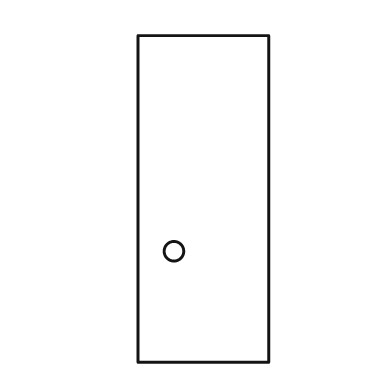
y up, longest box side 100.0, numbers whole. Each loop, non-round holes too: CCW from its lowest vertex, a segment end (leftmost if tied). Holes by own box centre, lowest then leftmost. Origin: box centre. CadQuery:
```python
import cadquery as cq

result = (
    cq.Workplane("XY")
    .moveTo(-20.0, -50.0)
    .lineTo(20.0, -50.0)
    .lineTo(20.0, 50.0)
    .lineTo(-20.0, 50.0)
    .close()
    .moveTo(-9.0, -16.0)
    .circle(3.0)
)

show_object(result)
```